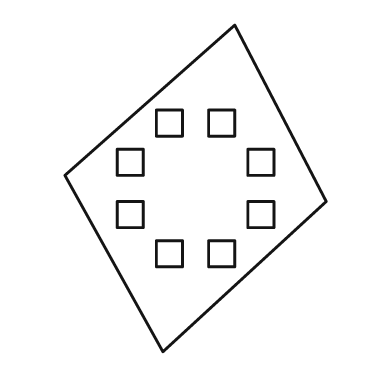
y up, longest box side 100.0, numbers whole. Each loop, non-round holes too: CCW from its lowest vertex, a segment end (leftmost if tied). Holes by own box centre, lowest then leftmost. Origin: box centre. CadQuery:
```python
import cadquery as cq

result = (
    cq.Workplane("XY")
    .moveTo(-10.0, -50.0)
    .lineTo(40.0, -4.0)
    .lineTo(12.0, 50.0)
    .lineTo(-40.0, 4.0)
    .close()
    .moveTo(-12.0, -24.0)
    .lineTo(-4.0, -24.0)
    .lineTo(-4.0, -16.0)
    .lineTo(-12.0, -16.0)
    .close()
    .moveTo(4.0, -24.0)
    .lineTo(12.0, -24.0)
    .lineTo(12.0, -16.0)
    .lineTo(4.0, -16.0)
    .close()
    .moveTo(-24.0, -12.0)
    .lineTo(-16.0, -12.0)
    .lineTo(-16.0, -4.0)
    .lineTo(-24.0, -4.0)
    .close()
    .moveTo(16.0, -12.0)
    .lineTo(24.0, -12.0)
    .lineTo(24.0, -4.0)
    .lineTo(16.0, -4.0)
    .close()
    .moveTo(-24.0, 4.0)
    .lineTo(-16.0, 4.0)
    .lineTo(-16.0, 12.0)
    .lineTo(-24.0, 12.0)
    .close()
    .moveTo(16.0, 4.0)
    .lineTo(24.0, 4.0)
    .lineTo(24.0, 12.0)
    .lineTo(16.0, 12.0)
    .close()
    .moveTo(-12.0, 16.0)
    .lineTo(-4.0, 16.0)
    .lineTo(-4.0, 24.0)
    .lineTo(-12.0, 24.0)
    .close()
    .moveTo(4.0, 16.0)
    .lineTo(12.0, 16.0)
    .lineTo(12.0, 24.0)
    .lineTo(4.0, 24.0)
    .close()
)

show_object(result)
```